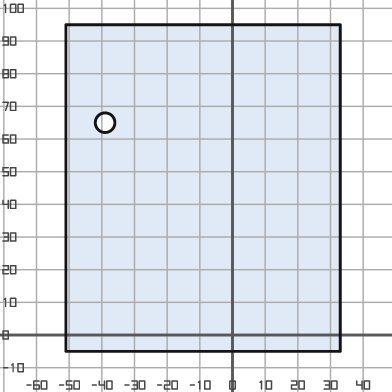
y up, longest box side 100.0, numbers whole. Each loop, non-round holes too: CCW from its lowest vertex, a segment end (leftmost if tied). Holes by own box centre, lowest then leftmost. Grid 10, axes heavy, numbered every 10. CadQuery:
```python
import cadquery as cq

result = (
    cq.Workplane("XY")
    .moveTo(-51.0, -5.0)
    .lineTo(33.0, -5.0)
    .lineTo(33.0, 95.0)
    .lineTo(-51.0, 95.0)
    .close()
    .moveTo(-39.0, 65.0)
    .circle(3.0)
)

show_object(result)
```